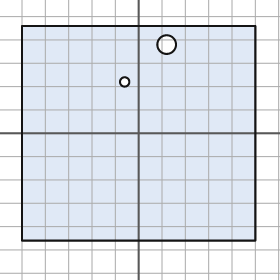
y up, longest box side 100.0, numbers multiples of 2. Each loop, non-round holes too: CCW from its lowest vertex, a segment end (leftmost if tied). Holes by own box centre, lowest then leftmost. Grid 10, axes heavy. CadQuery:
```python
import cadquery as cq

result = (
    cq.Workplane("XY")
    .moveTo(-50.0, -46.0)
    .lineTo(50.0, -46.0)
    .lineTo(50.0, 46.0)
    .lineTo(-50.0, 46.0)
    .close()
    .moveTo(-6.0, 22.0)
    .circle(2.0)
    .moveTo(12.0, 38.0)
    .circle(4.0)
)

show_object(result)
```